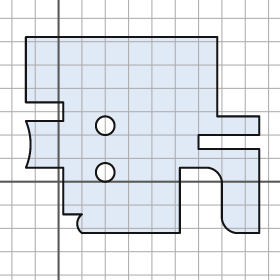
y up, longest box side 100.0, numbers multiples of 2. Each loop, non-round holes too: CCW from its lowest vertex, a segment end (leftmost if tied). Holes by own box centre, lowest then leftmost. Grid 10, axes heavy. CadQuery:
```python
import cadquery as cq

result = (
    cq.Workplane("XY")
    .moveTo(10.0, -22.0)
    .lineTo(52.0, -22.0)
    .lineTo(52.0, 6.0)
    .lineTo(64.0, 6.0)
    .threePointArc((68.0, 4.0), (70.0, 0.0))
    .lineTo(70.0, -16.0)
    .threePointArc((72.0, -20.0), (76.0, -22.0))
    .lineTo(86.0, -22.0)
    .lineTo(86.0, 14.0)
    .lineTo(60.0, 14.0)
    .lineTo(60.0, 20.0)
    .lineTo(86.0, 20.0)
    .lineTo(86.0, 28.0)
    .lineTo(68.0, 28.0)
    .lineTo(68.0, 62.0)
    .lineTo(-14.0, 62.0)
    .lineTo(-14.0, 34.0)
    .lineTo(2.0, 34.0)
    .lineTo(2.0, 26.0)
    .lineTo(-14.0, 26.0)
    .threePointArc((-12.0, 16.0), (-14.0, 6.0))
    .lineTo(2.0, 6.0)
    .lineTo(2.0, -14.0)
    .lineTo(10.0, -14.0)
    .threePointArc((8.0, -18.0), (10.0, -22.0))
    .close()
    .moveTo(20.0, 4.0)
    .circle(4.0)
    .moveTo(20.0, 24.0)
    .circle(4.0)
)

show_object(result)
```